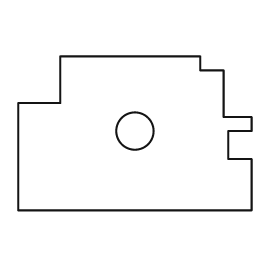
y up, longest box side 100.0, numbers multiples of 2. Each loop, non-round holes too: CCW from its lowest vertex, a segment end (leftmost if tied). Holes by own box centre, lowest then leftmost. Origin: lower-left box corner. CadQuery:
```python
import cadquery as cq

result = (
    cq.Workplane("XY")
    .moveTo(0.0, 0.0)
    .lineTo(100.0, 0.0)
    .lineTo(100.0, 22.0)
    .lineTo(90.0, 22.0)
    .lineTo(90.0, 34.0)
    .lineTo(100.0, 34.0)
    .lineTo(100.0, 40.0)
    .lineTo(88.0, 40.0)
    .lineTo(88.0, 60.0)
    .lineTo(78.0, 60.0)
    .lineTo(78.0, 66.0)
    .lineTo(18.0, 66.0)
    .lineTo(18.0, 46.0)
    .lineTo(0.0, 46.0)
    .close()
    .moveTo(50.0, 34.0)
    .circle(8.0)
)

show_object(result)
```